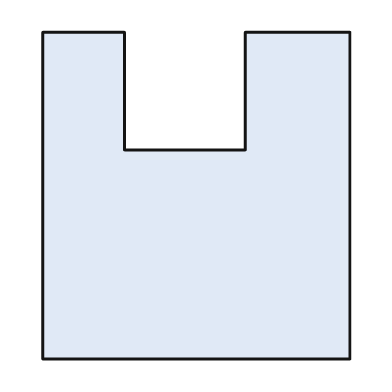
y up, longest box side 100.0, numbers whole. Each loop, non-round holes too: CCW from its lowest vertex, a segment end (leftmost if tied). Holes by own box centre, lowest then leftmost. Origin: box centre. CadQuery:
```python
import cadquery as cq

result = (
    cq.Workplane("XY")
    .moveTo(-47.0, -50.0)
    .lineTo(47.0, -50.0)
    .lineTo(47.0, 50.0)
    .lineTo(15.0, 50.0)
    .lineTo(15.0, 14.0)
    .lineTo(-22.0, 14.0)
    .lineTo(-22.0, 50.0)
    .lineTo(-47.0, 50.0)
    .close()
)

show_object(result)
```